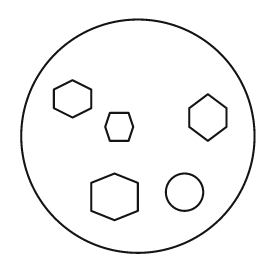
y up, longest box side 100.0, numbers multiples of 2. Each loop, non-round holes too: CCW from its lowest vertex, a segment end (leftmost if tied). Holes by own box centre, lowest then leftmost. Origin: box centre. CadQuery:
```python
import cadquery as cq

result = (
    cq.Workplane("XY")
    .moveTo(0.0, 0.0)
    .circle(50.0)
    .moveTo(-10.0, -36.0)
    .lineTo(0.0, -32.0)
    .lineTo(0.0, -20.0)
    .lineTo(-10.0, -16.0)
    .lineTo(-20.0, -20.0)
    .lineTo(-20.0, -32.0)
    .close()
    .moveTo(20.0, -24.0)
    .circle(8.0)
    .moveTo(-12.0, -2.0)
    .lineTo(-4.0, -2.0)
    .lineTo(-2.0, 4.0)
    .lineTo(-4.0, 10.0)
    .lineTo(-12.0, 10.0)
    .lineTo(-14.0, 4.0)
    .close()
    .moveTo(30.0, -2.0)
    .lineTo(38.0, 4.0)
    .lineTo(38.0, 12.0)
    .lineTo(30.0, 18.0)
    .lineTo(22.0, 12.0)
    .lineTo(22.0, 4.0)
    .close()
    .moveTo(-28.0, 8.0)
    .lineTo(-20.0, 12.0)
    .lineTo(-20.0, 20.0)
    .lineTo(-28.0, 24.0)
    .lineTo(-36.0, 20.0)
    .lineTo(-36.0, 12.0)
    .close()
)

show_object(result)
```